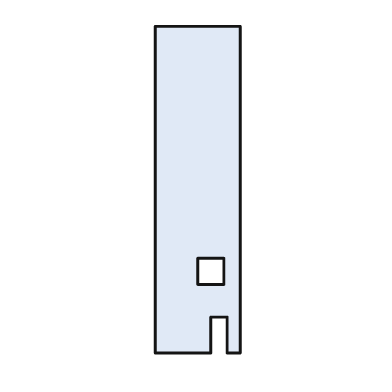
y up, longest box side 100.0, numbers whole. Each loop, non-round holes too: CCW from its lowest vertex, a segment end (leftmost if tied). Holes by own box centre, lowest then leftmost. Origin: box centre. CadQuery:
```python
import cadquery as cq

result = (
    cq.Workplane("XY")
    .moveTo(-13.0, -50.0)
    .lineTo(4.0, -50.0)
    .lineTo(4.0, -39.0)
    .lineTo(9.0, -39.0)
    .lineTo(9.0, -50.0)
    .lineTo(13.0, -50.0)
    .lineTo(13.0, 50.0)
    .lineTo(-13.0, 50.0)
    .close()
    .moveTo(0.0, -29.0)
    .lineTo(8.0, -29.0)
    .lineTo(8.0, -21.0)
    .lineTo(0.0, -21.0)
    .close()
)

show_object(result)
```